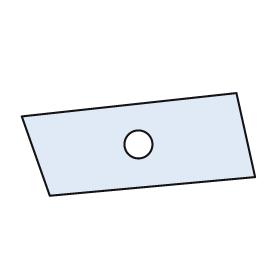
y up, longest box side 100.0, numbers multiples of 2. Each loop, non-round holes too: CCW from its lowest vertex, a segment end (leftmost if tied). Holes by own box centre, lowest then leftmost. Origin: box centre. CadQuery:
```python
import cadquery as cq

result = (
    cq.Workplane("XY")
    .moveTo(-38.0, -22.0)
    .lineTo(50.0, -14.0)
    .lineTo(42.0, 22.0)
    .lineTo(-50.0, 12.0)
    .close()
    .moveTo(0.0, 0.0)
    .circle(6.0)
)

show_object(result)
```